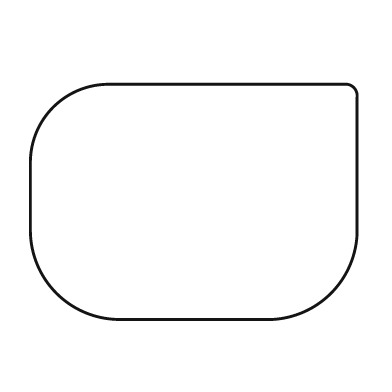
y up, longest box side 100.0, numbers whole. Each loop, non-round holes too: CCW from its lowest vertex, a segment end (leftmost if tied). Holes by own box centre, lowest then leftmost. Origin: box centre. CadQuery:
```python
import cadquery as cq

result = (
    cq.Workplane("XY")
    .moveTo(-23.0, -36.0)
    .lineTo(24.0, -36.0)
    .threePointArc((42.0, -28.0), (50.0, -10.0))
    .lineTo(50.0, 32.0)
    .threePointArc((49.0, 35.0), (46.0, 36.0))
    .lineTo(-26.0, 36.0)
    .threePointArc((-43.0, 29.0), (-50.0, 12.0))
    .lineTo(-50.0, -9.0)
    .threePointArc((-42.0, -28.0), (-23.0, -36.0))
    .close()
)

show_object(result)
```